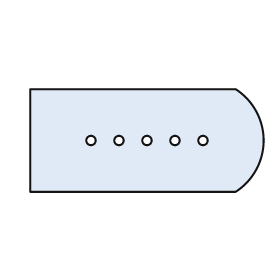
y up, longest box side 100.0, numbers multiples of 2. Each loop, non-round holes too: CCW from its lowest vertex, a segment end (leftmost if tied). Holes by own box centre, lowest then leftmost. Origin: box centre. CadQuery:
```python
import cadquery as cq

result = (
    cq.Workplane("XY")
    .moveTo(-50.0, -22.0)
    .lineTo(38.0, -22.0)
    .threePointArc((50.0, 0.0), (38.0, 22.0))
    .lineTo(-50.0, 22.0)
    .close()
    .moveTo(-24.0, 0.0)
    .circle(2.0)
    .moveTo(-12.0, 0.0)
    .circle(2.0)
    .moveTo(0.0, 0.0)
    .circle(2.0)
    .moveTo(12.0, 0.0)
    .circle(2.0)
    .moveTo(24.0, 0.0)
    .circle(2.0)
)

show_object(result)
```